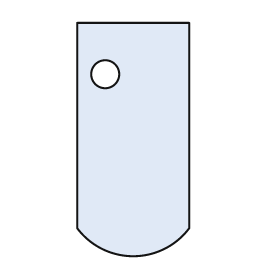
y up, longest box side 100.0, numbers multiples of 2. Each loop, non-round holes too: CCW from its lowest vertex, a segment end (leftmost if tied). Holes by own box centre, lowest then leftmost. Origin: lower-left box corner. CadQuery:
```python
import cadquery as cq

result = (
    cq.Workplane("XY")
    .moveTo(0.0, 12.0)
    .threePointArc((24.0, 0.0), (48.0, 12.0))
    .lineTo(48.0, 100.0)
    .lineTo(0.0, 100.0)
    .close()
    .moveTo(12.0, 78.0)
    .circle(6.0)
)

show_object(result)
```